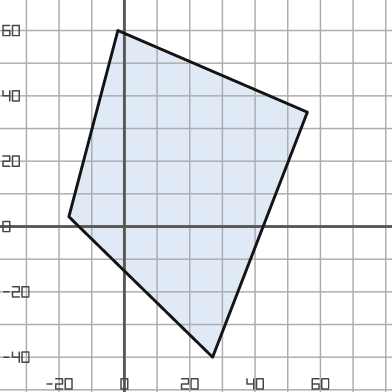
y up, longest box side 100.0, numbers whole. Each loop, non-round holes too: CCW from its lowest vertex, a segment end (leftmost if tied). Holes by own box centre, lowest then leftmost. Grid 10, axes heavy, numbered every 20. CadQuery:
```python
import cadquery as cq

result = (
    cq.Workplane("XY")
    .moveTo(27.0, -40.0)
    .lineTo(56.0, 35.0)
    .lineTo(-2.0, 60.0)
    .lineTo(-17.0, 3.0)
    .close()
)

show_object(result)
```